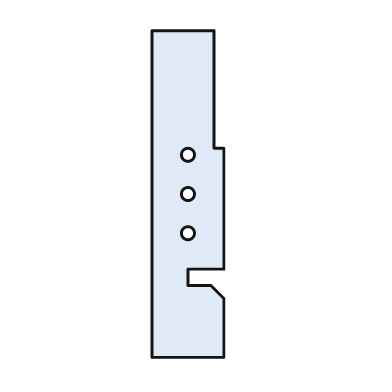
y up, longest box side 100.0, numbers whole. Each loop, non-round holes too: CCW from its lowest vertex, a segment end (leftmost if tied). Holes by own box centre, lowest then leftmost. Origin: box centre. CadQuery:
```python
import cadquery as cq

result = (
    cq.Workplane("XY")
    .moveTo(-11.0, -50.0)
    .lineTo(11.0, -50.0)
    .lineTo(11.0, -32.0)
    .lineTo(7.0, -28.0)
    .lineTo(0.0, -28.0)
    .lineTo(0.0, -23.0)
    .lineTo(11.0, -23.0)
    .lineTo(11.0, 14.0)
    .lineTo(8.0, 14.0)
    .lineTo(8.0, 50.0)
    .lineTo(-11.0, 50.0)
    .close()
    .moveTo(0.0, -12.0)
    .circle(2.0)
    .moveTo(0.0, 0.0)
    .circle(2.0)
    .moveTo(0.0, 12.0)
    .circle(2.0)
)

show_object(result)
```